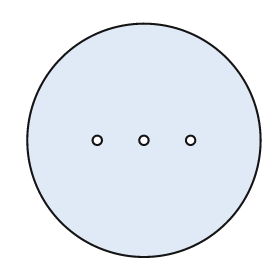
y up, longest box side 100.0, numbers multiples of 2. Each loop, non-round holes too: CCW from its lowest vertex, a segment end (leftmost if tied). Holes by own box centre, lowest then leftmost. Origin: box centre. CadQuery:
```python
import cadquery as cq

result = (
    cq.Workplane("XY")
    .moveTo(0.0, 0.0)
    .circle(50.0)
    .moveTo(-20.0, 0.0)
    .circle(2.0)
    .moveTo(0.0, 0.0)
    .circle(2.0)
    .moveTo(20.0, 0.0)
    .circle(2.0)
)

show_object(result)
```